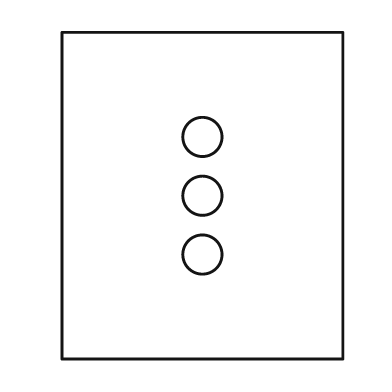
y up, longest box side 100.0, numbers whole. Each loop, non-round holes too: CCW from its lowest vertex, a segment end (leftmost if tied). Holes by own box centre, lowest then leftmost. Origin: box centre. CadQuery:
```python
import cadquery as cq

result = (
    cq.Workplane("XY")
    .moveTo(-43.0, -50.0)
    .lineTo(43.0, -50.0)
    .lineTo(43.0, 50.0)
    .lineTo(-43.0, 50.0)
    .close()
    .moveTo(0.0, -18.0)
    .circle(6.0)
    .moveTo(0.0, 0.0)
    .circle(6.0)
    .moveTo(0.0, 18.0)
    .circle(6.0)
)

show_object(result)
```